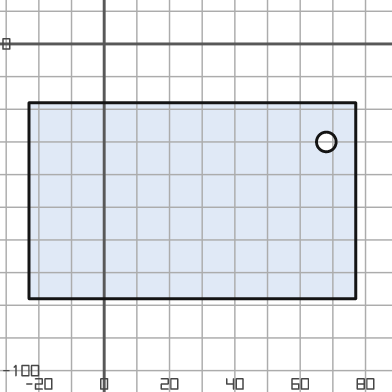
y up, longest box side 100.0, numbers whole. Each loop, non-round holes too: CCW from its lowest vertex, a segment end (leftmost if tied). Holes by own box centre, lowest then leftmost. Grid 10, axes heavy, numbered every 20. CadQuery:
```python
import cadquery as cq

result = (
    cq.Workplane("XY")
    .moveTo(-23.0, -78.0)
    .lineTo(77.0, -78.0)
    .lineTo(77.0, -18.0)
    .lineTo(-23.0, -18.0)
    .close()
    .moveTo(68.0, -30.0)
    .circle(3.0)
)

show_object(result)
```